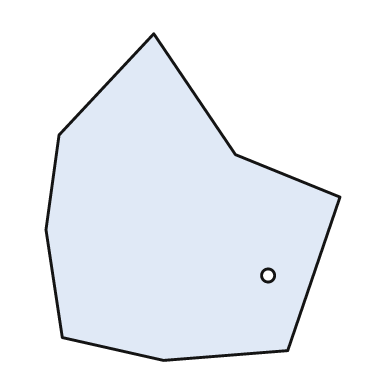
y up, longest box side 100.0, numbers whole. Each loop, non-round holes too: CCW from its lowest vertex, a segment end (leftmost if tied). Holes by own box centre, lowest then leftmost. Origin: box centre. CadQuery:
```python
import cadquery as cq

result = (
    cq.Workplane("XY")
    .moveTo(-9.0, -50.0)
    .lineTo(29.0, -47.0)
    .lineTo(45.0, 0.0)
    .lineTo(13.0, 13.0)
    .lineTo(-12.0, 50.0)
    .lineTo(-41.0, 19.0)
    .lineTo(-45.0, -10.0)
    .lineTo(-40.0, -43.0)
    .close()
    .moveTo(23.0, -24.0)
    .circle(2.0)
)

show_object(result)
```